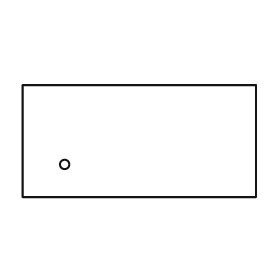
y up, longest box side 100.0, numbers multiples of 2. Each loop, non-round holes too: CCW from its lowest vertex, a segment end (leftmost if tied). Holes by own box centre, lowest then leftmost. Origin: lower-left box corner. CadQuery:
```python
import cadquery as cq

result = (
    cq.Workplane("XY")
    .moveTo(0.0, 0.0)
    .lineTo(100.0, 0.0)
    .lineTo(100.0, 48.0)
    .lineTo(0.0, 48.0)
    .close()
    .moveTo(18.0, 14.0)
    .circle(2.0)
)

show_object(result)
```